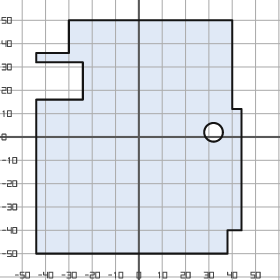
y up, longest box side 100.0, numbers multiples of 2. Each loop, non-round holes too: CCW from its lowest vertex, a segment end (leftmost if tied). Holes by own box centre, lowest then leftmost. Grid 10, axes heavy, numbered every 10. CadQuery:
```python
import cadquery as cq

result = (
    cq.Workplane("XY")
    .moveTo(-44.0, -50.0)
    .lineTo(38.0, -50.0)
    .lineTo(38.0, -40.0)
    .lineTo(44.0, -40.0)
    .lineTo(44.0, 12.0)
    .lineTo(40.0, 12.0)
    .lineTo(40.0, 50.0)
    .lineTo(-30.0, 50.0)
    .lineTo(-30.0, 36.0)
    .lineTo(-44.0, 36.0)
    .lineTo(-44.0, 32.0)
    .lineTo(-24.0, 32.0)
    .lineTo(-24.0, 16.0)
    .lineTo(-44.0, 16.0)
    .close()
    .moveTo(32.0, 2.0)
    .circle(4.0)
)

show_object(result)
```